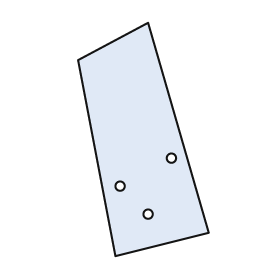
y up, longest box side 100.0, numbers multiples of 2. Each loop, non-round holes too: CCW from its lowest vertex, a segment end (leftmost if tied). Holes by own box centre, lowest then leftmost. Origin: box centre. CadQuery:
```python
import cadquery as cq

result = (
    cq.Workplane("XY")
    .moveTo(-12.0, -50.0)
    .lineTo(28.0, -40.0)
    .lineTo(2.0, 50.0)
    .lineTo(-28.0, 34.0)
    .close()
    .moveTo(2.0, -32.0)
    .circle(2.0)
    .moveTo(-10.0, -20.0)
    .circle(2.0)
    .moveTo(12.0, -8.0)
    .circle(2.0)
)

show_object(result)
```